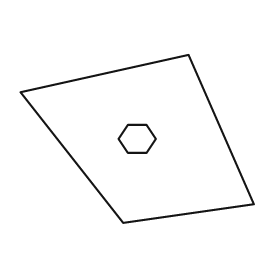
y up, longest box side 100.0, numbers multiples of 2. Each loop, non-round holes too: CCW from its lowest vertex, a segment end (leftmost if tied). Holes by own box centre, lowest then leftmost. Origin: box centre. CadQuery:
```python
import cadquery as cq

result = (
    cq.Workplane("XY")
    .moveTo(-6.0, -36.0)
    .lineTo(50.0, -28.0)
    .lineTo(22.0, 36.0)
    .lineTo(-50.0, 20.0)
    .close()
    .moveTo(-4.0, -6.0)
    .lineTo(4.0, -6.0)
    .lineTo(8.0, 0.0)
    .lineTo(4.0, 6.0)
    .lineTo(-4.0, 6.0)
    .lineTo(-8.0, 0.0)
    .close()
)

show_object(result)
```